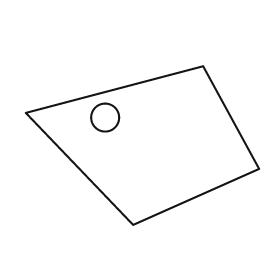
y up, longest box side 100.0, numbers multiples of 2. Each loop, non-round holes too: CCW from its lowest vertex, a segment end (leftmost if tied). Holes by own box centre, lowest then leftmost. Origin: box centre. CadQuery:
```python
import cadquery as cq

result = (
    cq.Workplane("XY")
    .moveTo(-4.0, -34.0)
    .lineTo(50.0, -10.0)
    .lineTo(26.0, 34.0)
    .lineTo(-50.0, 14.0)
    .close()
    .moveTo(-16.0, 12.0)
    .circle(6.0)
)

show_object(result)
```